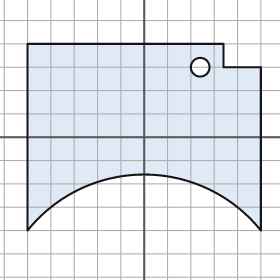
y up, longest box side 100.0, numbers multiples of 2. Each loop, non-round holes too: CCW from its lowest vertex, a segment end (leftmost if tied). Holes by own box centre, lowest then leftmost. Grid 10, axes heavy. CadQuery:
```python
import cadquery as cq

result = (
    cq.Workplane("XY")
    .moveTo(-50.0, -40.0)
    .threePointArc((0.0, -16.0), (50.0, -40.0))
    .lineTo(50.0, 30.0)
    .lineTo(34.0, 30.0)
    .lineTo(34.0, 40.0)
    .lineTo(-50.0, 40.0)
    .close()
    .moveTo(24.0, 30.0)
    .circle(4.0)
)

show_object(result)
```